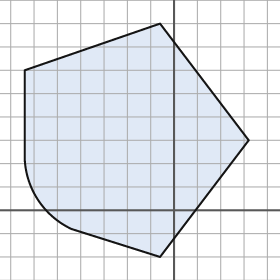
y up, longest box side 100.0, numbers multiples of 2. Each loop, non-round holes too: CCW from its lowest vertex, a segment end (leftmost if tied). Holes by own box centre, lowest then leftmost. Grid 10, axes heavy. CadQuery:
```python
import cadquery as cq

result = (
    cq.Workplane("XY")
    .moveTo(-6.0, -20.0)
    .lineTo(32.0, 30.0)
    .lineTo(-6.0, 80.0)
    .lineTo(-64.0, 60.0)
    .lineTo(-64.0, 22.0)
    .threePointArc((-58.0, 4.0), (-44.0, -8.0))
    .close()
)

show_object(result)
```